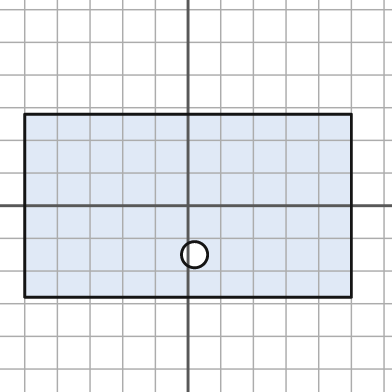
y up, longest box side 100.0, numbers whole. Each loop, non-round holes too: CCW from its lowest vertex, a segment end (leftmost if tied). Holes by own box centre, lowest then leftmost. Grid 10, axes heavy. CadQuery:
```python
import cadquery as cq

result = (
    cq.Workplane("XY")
    .moveTo(-50.0, -28.0)
    .lineTo(50.0, -28.0)
    .lineTo(50.0, 28.0)
    .lineTo(-50.0, 28.0)
    .close()
    .moveTo(2.0, -15.0)
    .circle(4.0)
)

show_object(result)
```